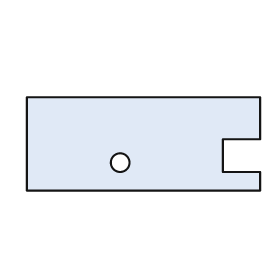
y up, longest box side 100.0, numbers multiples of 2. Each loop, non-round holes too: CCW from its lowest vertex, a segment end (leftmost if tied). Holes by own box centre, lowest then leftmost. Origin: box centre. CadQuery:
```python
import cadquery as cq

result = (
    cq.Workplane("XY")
    .moveTo(-50.0, -20.0)
    .lineTo(50.0, -20.0)
    .lineTo(50.0, -12.0)
    .lineTo(34.0, -12.0)
    .lineTo(34.0, 2.0)
    .lineTo(50.0, 2.0)
    .lineTo(50.0, 20.0)
    .lineTo(-50.0, 20.0)
    .close()
    .moveTo(-10.0, -8.0)
    .circle(4.0)
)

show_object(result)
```